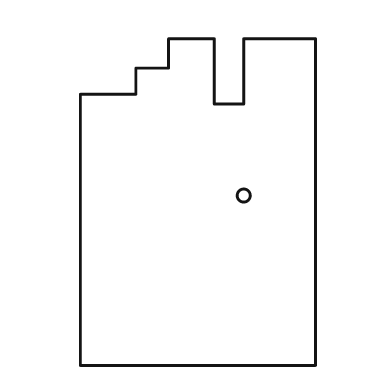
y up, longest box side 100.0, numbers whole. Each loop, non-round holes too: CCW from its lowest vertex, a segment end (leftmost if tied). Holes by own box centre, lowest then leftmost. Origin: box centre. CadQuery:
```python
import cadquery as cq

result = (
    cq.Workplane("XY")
    .moveTo(-36.0, -50.0)
    .lineTo(36.0, -50.0)
    .lineTo(36.0, 50.0)
    .lineTo(14.0, 50.0)
    .lineTo(14.0, 30.0)
    .lineTo(5.0, 30.0)
    .lineTo(5.0, 50.0)
    .lineTo(-9.0, 50.0)
    .lineTo(-9.0, 41.0)
    .lineTo(-19.0, 41.0)
    .lineTo(-19.0, 33.0)
    .lineTo(-36.0, 33.0)
    .close()
    .moveTo(14.0, 2.0)
    .circle(2.0)
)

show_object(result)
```